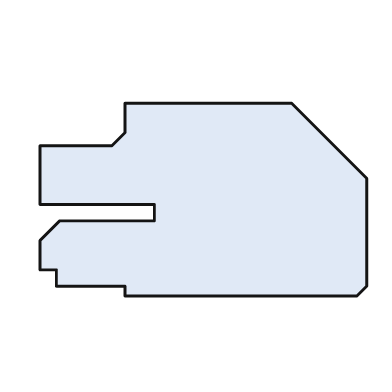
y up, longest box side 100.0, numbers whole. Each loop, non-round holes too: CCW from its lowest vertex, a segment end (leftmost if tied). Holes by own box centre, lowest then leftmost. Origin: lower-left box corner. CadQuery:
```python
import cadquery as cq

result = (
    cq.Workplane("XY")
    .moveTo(26.0, 0.0)
    .lineTo(97.0, 0.0)
    .lineTo(100.0, 3.0)
    .lineTo(100.0, 36.0)
    .lineTo(77.0, 59.0)
    .lineTo(26.0, 59.0)
    .lineTo(26.0, 50.0)
    .lineTo(22.0, 46.0)
    .lineTo(0.0, 46.0)
    .lineTo(0.0, 28.0)
    .lineTo(35.0, 28.0)
    .lineTo(35.0, 23.0)
    .lineTo(6.0, 23.0)
    .lineTo(0.0, 17.0)
    .lineTo(0.0, 8.0)
    .lineTo(5.0, 8.0)
    .lineTo(5.0, 3.0)
    .lineTo(26.0, 3.0)
    .close()
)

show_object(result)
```